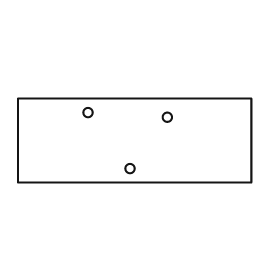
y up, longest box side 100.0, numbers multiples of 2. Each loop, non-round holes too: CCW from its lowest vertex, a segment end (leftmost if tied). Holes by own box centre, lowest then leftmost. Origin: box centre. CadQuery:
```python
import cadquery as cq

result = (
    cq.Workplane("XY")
    .moveTo(-50.0, -18.0)
    .lineTo(50.0, -18.0)
    .lineTo(50.0, 18.0)
    .lineTo(-50.0, 18.0)
    .close()
    .moveTo(-2.0, -12.0)
    .circle(2.0)
    .moveTo(14.0, 10.0)
    .circle(2.0)
    .moveTo(-20.0, 12.0)
    .circle(2.0)
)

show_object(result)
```